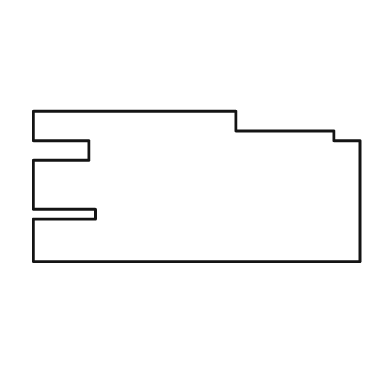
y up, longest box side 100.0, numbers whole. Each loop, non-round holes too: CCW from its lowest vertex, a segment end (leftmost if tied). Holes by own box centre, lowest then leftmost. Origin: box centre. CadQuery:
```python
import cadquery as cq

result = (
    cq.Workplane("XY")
    .moveTo(-50.0, -23.0)
    .lineTo(50.0, -23.0)
    .lineTo(50.0, 14.0)
    .lineTo(42.0, 14.0)
    .lineTo(42.0, 17.0)
    .lineTo(12.0, 17.0)
    .lineTo(12.0, 23.0)
    .lineTo(-50.0, 23.0)
    .lineTo(-50.0, 14.0)
    .lineTo(-33.0, 14.0)
    .lineTo(-33.0, 8.0)
    .lineTo(-50.0, 8.0)
    .lineTo(-50.0, -7.0)
    .lineTo(-31.0, -7.0)
    .lineTo(-31.0, -10.0)
    .lineTo(-50.0, -10.0)
    .close()
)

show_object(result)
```